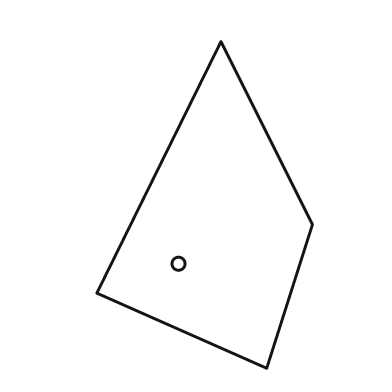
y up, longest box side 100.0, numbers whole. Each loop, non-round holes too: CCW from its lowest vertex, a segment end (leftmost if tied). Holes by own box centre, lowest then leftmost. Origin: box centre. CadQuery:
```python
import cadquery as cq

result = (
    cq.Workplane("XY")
    .moveTo(19.0, -50.0)
    .lineTo(33.0, -6.0)
    .lineTo(5.0, 50.0)
    .lineTo(-33.0, -27.0)
    .close()
    .moveTo(-8.0, -18.0)
    .circle(2.0)
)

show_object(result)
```